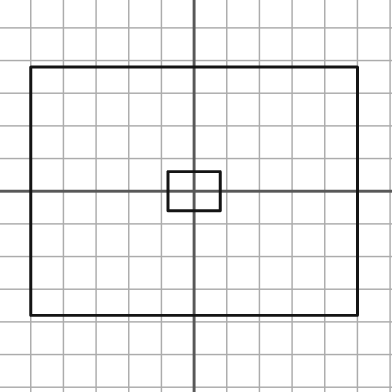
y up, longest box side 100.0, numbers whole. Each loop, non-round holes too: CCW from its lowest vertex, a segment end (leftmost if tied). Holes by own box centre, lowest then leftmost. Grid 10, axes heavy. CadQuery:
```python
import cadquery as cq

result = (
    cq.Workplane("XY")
    .moveTo(-50.0, -38.0)
    .lineTo(50.0, -38.0)
    .lineTo(50.0, 38.0)
    .lineTo(-50.0, 38.0)
    .close()
    .moveTo(-8.0, -6.0)
    .lineTo(8.0, -6.0)
    .lineTo(8.0, 6.0)
    .lineTo(-8.0, 6.0)
    .close()
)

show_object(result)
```